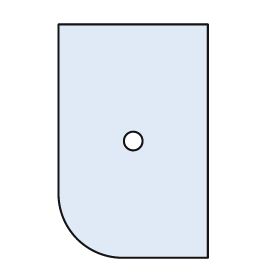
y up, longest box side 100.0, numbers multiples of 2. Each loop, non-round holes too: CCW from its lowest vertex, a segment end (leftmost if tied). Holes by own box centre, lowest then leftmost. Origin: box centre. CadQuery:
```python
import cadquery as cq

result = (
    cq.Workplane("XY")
    .moveTo(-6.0, -50.0)
    .lineTo(32.0, -50.0)
    .lineTo(32.0, 50.0)
    .lineTo(-32.0, 50.0)
    .lineTo(-32.0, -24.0)
    .threePointArc((-24.0, -42.0), (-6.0, -50.0))
    .close()
    .moveTo(0.0, 0.0)
    .circle(4.0)
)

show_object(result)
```